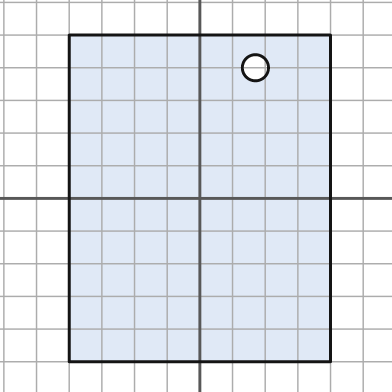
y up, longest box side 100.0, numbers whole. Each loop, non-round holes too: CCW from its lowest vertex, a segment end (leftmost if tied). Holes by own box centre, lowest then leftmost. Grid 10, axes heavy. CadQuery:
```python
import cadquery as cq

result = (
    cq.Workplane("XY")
    .moveTo(-40.0, -50.0)
    .lineTo(40.0, -50.0)
    .lineTo(40.0, 50.0)
    .lineTo(-40.0, 50.0)
    .close()
    .moveTo(17.0, 40.0)
    .circle(4.0)
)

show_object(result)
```